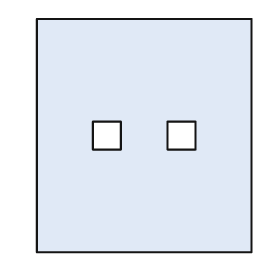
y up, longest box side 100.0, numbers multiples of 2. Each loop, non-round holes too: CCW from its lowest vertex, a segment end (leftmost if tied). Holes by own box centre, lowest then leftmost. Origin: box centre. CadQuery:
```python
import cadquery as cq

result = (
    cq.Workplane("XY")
    .moveTo(-46.0, -50.0)
    .lineTo(46.0, -50.0)
    .lineTo(46.0, 50.0)
    .lineTo(-46.0, 50.0)
    .close()
    .moveTo(-22.0, -6.0)
    .lineTo(-10.0, -6.0)
    .lineTo(-10.0, 6.0)
    .lineTo(-22.0, 6.0)
    .close()
    .moveTo(10.0, -6.0)
    .lineTo(22.0, -6.0)
    .lineTo(22.0, 6.0)
    .lineTo(10.0, 6.0)
    .close()
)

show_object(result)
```